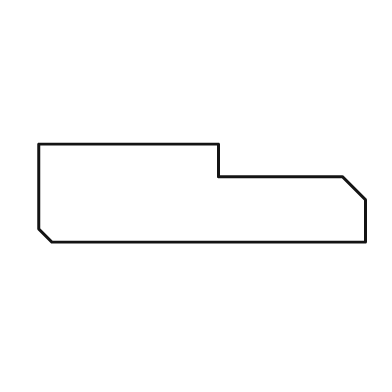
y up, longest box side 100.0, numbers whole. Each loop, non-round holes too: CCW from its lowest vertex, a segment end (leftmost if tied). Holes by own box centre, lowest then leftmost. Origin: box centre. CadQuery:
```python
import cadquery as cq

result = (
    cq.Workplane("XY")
    .moveTo(-46.0, -15.0)
    .lineTo(50.0, -15.0)
    .lineTo(50.0, -2.0)
    .lineTo(43.0, 5.0)
    .lineTo(5.0, 5.0)
    .lineTo(5.0, 15.0)
    .lineTo(-50.0, 15.0)
    .lineTo(-50.0, -11.0)
    .close()
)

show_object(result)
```